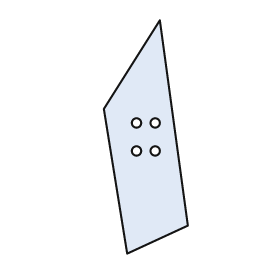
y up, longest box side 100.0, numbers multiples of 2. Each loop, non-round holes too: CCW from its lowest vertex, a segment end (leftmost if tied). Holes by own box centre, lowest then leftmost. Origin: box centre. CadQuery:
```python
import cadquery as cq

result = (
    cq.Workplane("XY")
    .moveTo(-8.0, -50.0)
    .lineTo(18.0, -38.0)
    .lineTo(6.0, 50.0)
    .lineTo(-18.0, 12.0)
    .close()
    .moveTo(-4.0, -6.0)
    .circle(2.0)
    .moveTo(4.0, -6.0)
    .circle(2.0)
    .moveTo(-4.0, 6.0)
    .circle(2.0)
    .moveTo(4.0, 6.0)
    .circle(2.0)
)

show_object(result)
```